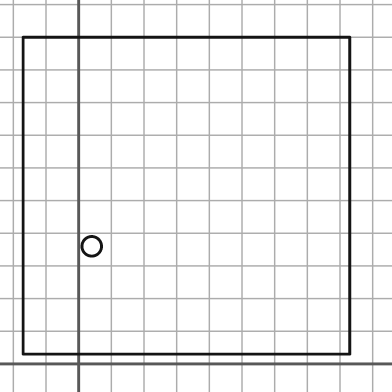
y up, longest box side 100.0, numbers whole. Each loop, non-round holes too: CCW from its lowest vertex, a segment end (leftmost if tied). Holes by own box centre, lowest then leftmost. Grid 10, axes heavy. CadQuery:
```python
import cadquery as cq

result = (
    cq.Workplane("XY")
    .moveTo(-17.0, 3.0)
    .lineTo(83.0, 3.0)
    .lineTo(83.0, 100.0)
    .lineTo(-17.0, 100.0)
    .close()
    .moveTo(4.0, 36.0)
    .circle(3.0)
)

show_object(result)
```